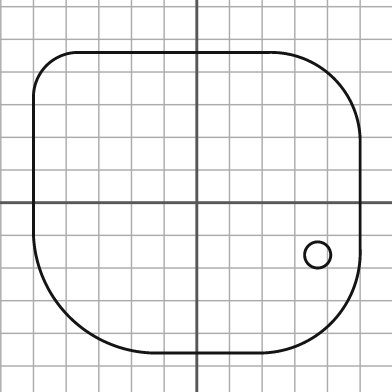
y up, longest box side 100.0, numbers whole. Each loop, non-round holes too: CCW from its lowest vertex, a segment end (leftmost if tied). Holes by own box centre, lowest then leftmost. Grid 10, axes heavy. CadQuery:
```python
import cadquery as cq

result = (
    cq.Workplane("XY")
    .moveTo(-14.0, -46.0)
    .lineTo(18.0, -46.0)
    .threePointArc((41.0, -37.0), (50.0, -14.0))
    .lineTo(50.0, 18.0)
    .threePointArc((42.0, 38.0), (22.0, 46.0))
    .lineTo(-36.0, 46.0)
    .threePointArc((-46.0, 42.0), (-50.0, 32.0))
    .lineTo(-50.0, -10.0)
    .threePointArc((-39.0, -35.0), (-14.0, -46.0))
    .close()
    .moveTo(37.0, -16.0)
    .circle(4.0)
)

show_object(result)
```